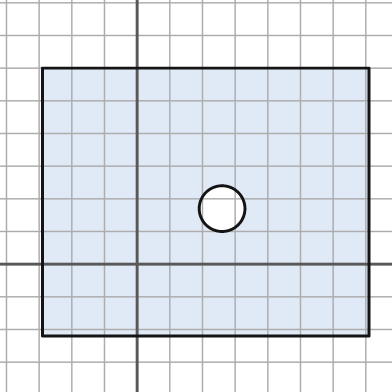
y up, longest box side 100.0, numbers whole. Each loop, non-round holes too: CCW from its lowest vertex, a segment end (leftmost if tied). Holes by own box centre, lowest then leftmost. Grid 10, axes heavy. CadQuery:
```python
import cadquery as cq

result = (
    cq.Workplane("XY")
    .moveTo(-29.0, -22.0)
    .lineTo(71.0, -22.0)
    .lineTo(71.0, 60.0)
    .lineTo(-29.0, 60.0)
    .close()
    .moveTo(26.0, 17.0)
    .circle(7.0)
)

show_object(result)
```